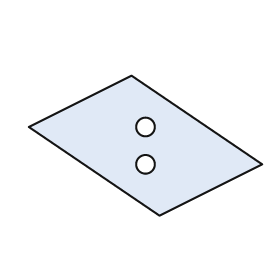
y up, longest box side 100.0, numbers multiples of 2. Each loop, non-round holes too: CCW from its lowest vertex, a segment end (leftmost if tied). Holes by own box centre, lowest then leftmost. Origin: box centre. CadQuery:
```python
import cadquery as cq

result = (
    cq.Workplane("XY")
    .moveTo(6.0, -30.0)
    .lineTo(50.0, -8.0)
    .lineTo(-6.0, 30.0)
    .lineTo(-50.0, 8.0)
    .close()
    .moveTo(0.0, -8.0)
    .circle(4.0)
    .moveTo(0.0, 8.0)
    .circle(4.0)
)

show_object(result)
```